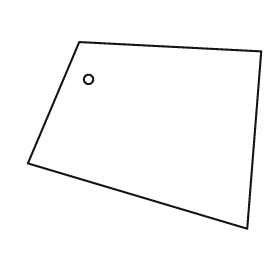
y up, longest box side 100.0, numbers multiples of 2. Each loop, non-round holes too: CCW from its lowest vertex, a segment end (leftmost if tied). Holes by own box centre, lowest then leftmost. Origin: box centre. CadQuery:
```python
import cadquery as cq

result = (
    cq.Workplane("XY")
    .moveTo(44.0, -40.0)
    .lineTo(50.0, 36.0)
    .lineTo(-28.0, 40.0)
    .lineTo(-50.0, -12.0)
    .close()
    .moveTo(-24.0, 24.0)
    .circle(2.0)
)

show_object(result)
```